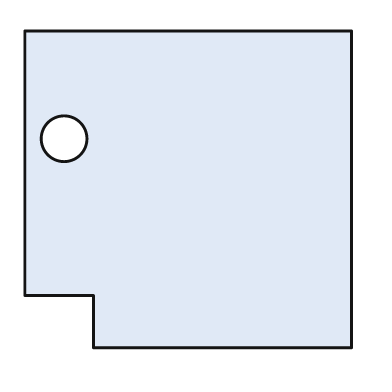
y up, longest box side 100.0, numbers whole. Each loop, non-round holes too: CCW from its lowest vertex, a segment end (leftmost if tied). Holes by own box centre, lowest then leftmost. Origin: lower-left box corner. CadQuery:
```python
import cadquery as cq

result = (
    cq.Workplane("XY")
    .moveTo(21.0, 0.0)
    .lineTo(100.0, 0.0)
    .lineTo(100.0, 97.0)
    .lineTo(0.0, 97.0)
    .lineTo(0.0, 16.0)
    .lineTo(21.0, 16.0)
    .close()
    .moveTo(12.0, 64.0)
    .circle(7.0)
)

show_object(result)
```